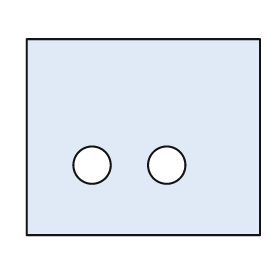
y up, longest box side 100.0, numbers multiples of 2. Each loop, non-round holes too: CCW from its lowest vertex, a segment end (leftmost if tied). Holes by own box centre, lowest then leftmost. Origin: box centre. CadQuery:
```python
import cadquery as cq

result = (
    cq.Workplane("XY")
    .moveTo(-50.0, -42.0)
    .lineTo(50.0, -42.0)
    .lineTo(50.0, 42.0)
    .lineTo(-50.0, 42.0)
    .close()
    .moveTo(-22.0, -12.0)
    .circle(8.0)
    .moveTo(10.0, -12.0)
    .circle(8.0)
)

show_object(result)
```